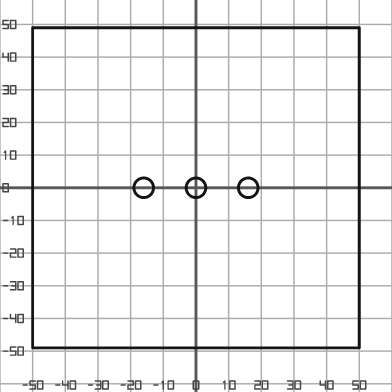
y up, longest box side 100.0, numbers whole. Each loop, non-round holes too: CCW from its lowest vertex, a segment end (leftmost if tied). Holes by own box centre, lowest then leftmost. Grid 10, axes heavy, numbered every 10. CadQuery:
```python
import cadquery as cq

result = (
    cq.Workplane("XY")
    .moveTo(-50.0, -49.0)
    .lineTo(50.0, -49.0)
    .lineTo(50.0, 49.0)
    .lineTo(-50.0, 49.0)
    .close()
    .moveTo(-16.0, 0.0)
    .circle(3.0)
    .moveTo(0.0, 0.0)
    .circle(3.0)
    .moveTo(16.0, 0.0)
    .circle(3.0)
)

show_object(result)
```